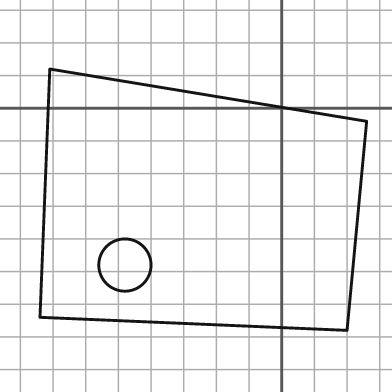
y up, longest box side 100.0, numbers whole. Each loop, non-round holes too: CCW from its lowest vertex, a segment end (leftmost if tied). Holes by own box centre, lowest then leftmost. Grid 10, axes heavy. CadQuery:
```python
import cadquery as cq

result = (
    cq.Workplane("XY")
    .moveTo(20.0, -68.0)
    .lineTo(26.0, -4.0)
    .lineTo(-71.0, 12.0)
    .lineTo(-74.0, -64.0)
    .close()
    .moveTo(-48.0, -48.0)
    .circle(8.0)
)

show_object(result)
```